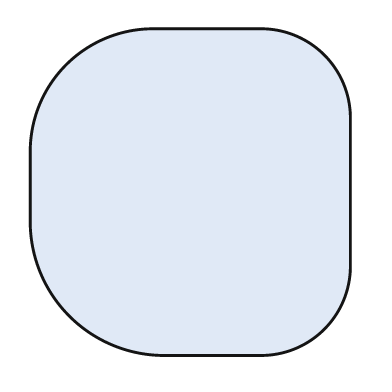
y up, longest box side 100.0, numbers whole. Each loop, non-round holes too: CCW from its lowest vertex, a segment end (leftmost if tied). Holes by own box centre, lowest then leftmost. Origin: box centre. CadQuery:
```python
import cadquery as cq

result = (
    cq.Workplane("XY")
    .moveTo(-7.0, -50.0)
    .lineTo(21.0, -50.0)
    .threePointArc((41.0, -42.0), (49.0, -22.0))
    .lineTo(49.0, 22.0)
    .threePointArc((41.0, 42.0), (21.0, 50.0))
    .lineTo(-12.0, 50.0)
    .threePointArc((-38.0, 39.0), (-49.0, 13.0))
    .lineTo(-49.0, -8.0)
    .threePointArc((-37.0, -38.0), (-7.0, -50.0))
    .close()
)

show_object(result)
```